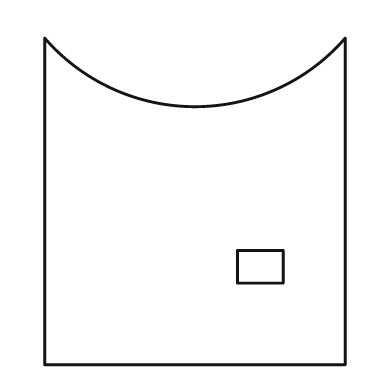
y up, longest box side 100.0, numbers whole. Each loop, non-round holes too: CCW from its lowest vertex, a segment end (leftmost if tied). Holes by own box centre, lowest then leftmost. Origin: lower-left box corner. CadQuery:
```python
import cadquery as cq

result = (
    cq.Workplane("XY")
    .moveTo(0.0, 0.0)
    .lineTo(92.0, 0.0)
    .lineTo(92.0, 100.0)
    .threePointArc((46.0, 79.0), (0.0, 100.0))
    .close()
    .moveTo(59.0, 25.0)
    .lineTo(73.0, 25.0)
    .lineTo(73.0, 35.0)
    .lineTo(59.0, 35.0)
    .close()
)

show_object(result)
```